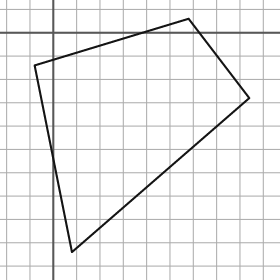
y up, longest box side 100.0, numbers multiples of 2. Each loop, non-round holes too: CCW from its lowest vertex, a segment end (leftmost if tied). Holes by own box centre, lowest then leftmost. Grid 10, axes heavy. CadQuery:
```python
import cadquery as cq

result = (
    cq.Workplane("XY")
    .moveTo(8.0, -94.0)
    .lineTo(84.0, -28.0)
    .lineTo(58.0, 6.0)
    .lineTo(-8.0, -14.0)
    .close()
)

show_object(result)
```